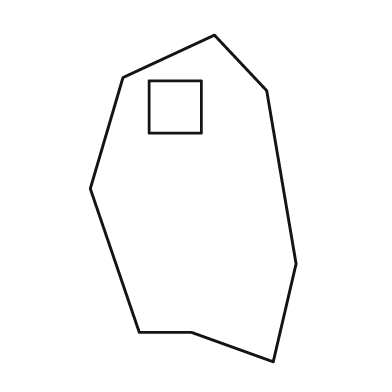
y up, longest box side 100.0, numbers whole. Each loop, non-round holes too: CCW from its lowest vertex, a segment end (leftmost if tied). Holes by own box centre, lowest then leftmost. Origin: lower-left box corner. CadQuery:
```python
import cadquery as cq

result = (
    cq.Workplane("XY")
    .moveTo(56.0, 0.0)
    .lineTo(63.0, 30.0)
    .lineTo(54.0, 83.0)
    .lineTo(38.0, 100.0)
    .lineTo(10.0, 87.0)
    .lineTo(0.0, 53.0)
    .lineTo(15.0, 9.0)
    .lineTo(31.0, 9.0)
    .close()
    .moveTo(18.0, 70.0)
    .lineTo(34.0, 70.0)
    .lineTo(34.0, 86.0)
    .lineTo(18.0, 86.0)
    .close()
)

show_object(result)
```